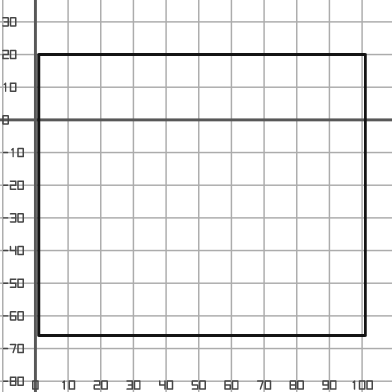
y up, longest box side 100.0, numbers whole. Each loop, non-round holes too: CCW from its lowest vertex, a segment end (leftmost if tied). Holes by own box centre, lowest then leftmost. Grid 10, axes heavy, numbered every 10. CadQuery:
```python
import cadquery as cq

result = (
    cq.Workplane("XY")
    .moveTo(1.0, -66.0)
    .lineTo(101.0, -66.0)
    .lineTo(101.0, 20.0)
    .lineTo(1.0, 20.0)
    .close()
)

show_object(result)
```